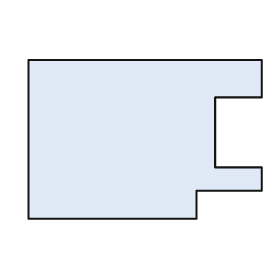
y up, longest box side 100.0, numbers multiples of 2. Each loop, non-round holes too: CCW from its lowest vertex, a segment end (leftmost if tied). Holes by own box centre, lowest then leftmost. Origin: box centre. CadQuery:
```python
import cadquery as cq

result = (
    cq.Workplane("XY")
    .moveTo(-50.0, -34.0)
    .lineTo(22.0, -34.0)
    .lineTo(22.0, -22.0)
    .lineTo(50.0, -22.0)
    .lineTo(50.0, -12.0)
    .lineTo(30.0, -12.0)
    .lineTo(30.0, 18.0)
    .lineTo(50.0, 18.0)
    .lineTo(50.0, 34.0)
    .lineTo(-50.0, 34.0)
    .close()
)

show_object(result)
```